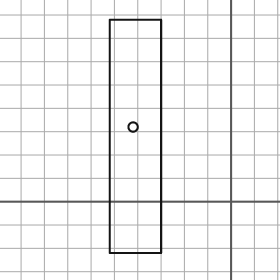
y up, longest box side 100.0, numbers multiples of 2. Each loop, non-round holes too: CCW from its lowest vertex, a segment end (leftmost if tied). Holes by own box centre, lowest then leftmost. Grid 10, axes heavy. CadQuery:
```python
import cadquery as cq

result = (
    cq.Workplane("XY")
    .moveTo(-52.0, -22.0)
    .lineTo(-30.0, -22.0)
    .lineTo(-30.0, 78.0)
    .lineTo(-52.0, 78.0)
    .close()
    .moveTo(-42.0, 32.0)
    .circle(2.0)
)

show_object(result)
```